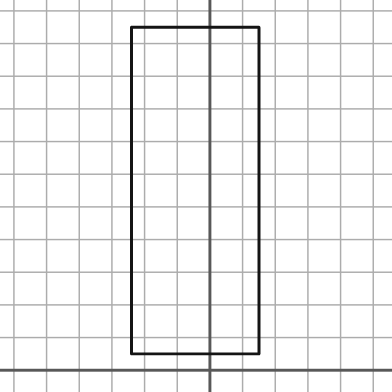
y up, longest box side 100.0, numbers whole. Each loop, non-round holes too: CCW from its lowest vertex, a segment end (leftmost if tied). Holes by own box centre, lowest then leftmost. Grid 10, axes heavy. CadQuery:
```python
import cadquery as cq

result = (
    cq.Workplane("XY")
    .moveTo(-24.0, 5.0)
    .lineTo(15.0, 5.0)
    .lineTo(15.0, 105.0)
    .lineTo(-24.0, 105.0)
    .close()
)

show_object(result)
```